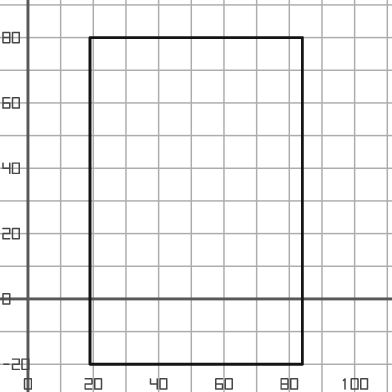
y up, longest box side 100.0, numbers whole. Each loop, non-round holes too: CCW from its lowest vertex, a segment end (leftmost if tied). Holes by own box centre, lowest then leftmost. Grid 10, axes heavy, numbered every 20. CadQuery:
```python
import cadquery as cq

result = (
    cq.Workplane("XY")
    .moveTo(19.0, -20.0)
    .lineTo(84.0, -20.0)
    .lineTo(84.0, 80.0)
    .lineTo(19.0, 80.0)
    .close()
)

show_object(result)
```